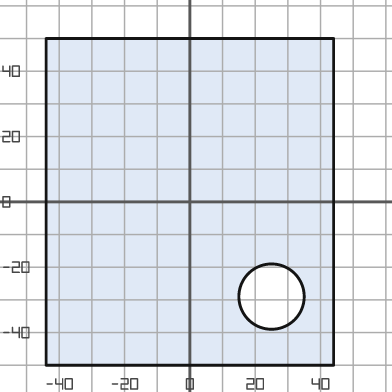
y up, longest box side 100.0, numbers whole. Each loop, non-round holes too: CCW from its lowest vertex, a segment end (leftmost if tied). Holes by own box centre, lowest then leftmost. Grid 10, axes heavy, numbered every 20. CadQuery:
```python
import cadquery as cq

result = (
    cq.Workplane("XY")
    .moveTo(-44.0, -50.0)
    .lineTo(44.0, -50.0)
    .lineTo(44.0, 50.0)
    .lineTo(-44.0, 50.0)
    .close()
    .moveTo(25.0, -29.0)
    .circle(10.0)
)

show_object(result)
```